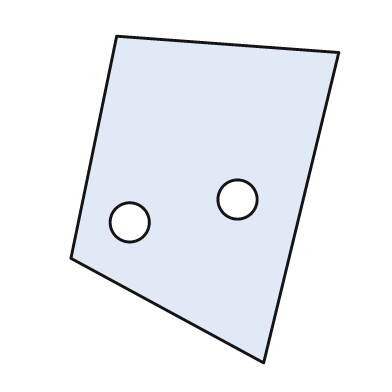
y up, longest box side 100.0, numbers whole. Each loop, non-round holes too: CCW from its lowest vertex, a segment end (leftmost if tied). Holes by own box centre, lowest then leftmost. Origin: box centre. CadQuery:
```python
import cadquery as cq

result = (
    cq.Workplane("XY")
    .moveTo(18.0, -50.0)
    .lineTo(41.0, 45.0)
    .lineTo(-27.0, 50.0)
    .lineTo(-41.0, -18.0)
    .close()
    .moveTo(-23.0, -7.0)
    .circle(6.0)
    .moveTo(10.0, 0.0)
    .circle(6.0)
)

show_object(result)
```